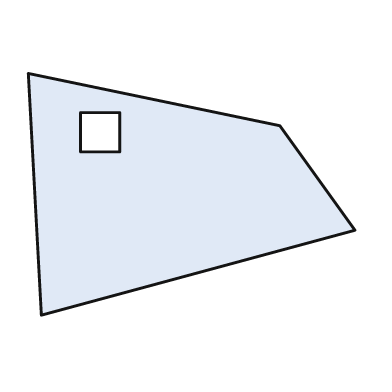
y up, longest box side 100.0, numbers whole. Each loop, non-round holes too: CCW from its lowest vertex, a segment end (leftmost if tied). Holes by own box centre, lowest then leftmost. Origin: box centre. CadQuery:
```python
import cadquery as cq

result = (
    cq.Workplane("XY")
    .moveTo(-46.0, -37.0)
    .lineTo(50.0, -11.0)
    .lineTo(27.0, 21.0)
    .lineTo(-50.0, 37.0)
    .close()
    .moveTo(-34.0, 13.0)
    .lineTo(-22.0, 13.0)
    .lineTo(-22.0, 25.0)
    .lineTo(-34.0, 25.0)
    .close()
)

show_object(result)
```